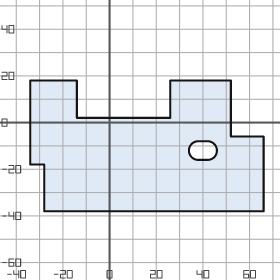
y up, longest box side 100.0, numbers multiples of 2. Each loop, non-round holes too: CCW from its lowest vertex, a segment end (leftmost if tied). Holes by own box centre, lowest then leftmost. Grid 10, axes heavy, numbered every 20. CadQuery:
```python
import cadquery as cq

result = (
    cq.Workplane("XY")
    .moveTo(-28.0, -38.0)
    .lineTo(66.0, -38.0)
    .lineTo(66.0, -6.0)
    .lineTo(52.0, -6.0)
    .lineTo(52.0, 18.0)
    .lineTo(26.0, 18.0)
    .lineTo(26.0, 2.0)
    .lineTo(-14.0, 2.0)
    .lineTo(-14.0, 18.0)
    .lineTo(-34.0, 18.0)
    .lineTo(-34.0, -18.0)
    .lineTo(-28.0, -18.0)
    .close()
    .moveTo(38.0, -16.0)
    .lineTo(42.0, -16.0)
    .threePointArc((46.0, -12.0), (42.0, -8.0))
    .lineTo(38.0, -8.0)
    .threePointArc((34.0, -12.0), (38.0, -16.0))
    .close()
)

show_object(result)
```